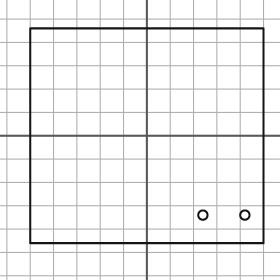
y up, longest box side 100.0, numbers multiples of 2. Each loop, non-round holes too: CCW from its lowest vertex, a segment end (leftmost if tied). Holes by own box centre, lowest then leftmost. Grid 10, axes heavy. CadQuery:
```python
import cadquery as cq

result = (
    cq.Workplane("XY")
    .moveTo(-50.0, -46.0)
    .lineTo(50.0, -46.0)
    .lineTo(50.0, 46.0)
    .lineTo(-50.0, 46.0)
    .close()
    .moveTo(24.0, -34.0)
    .circle(2.0)
    .moveTo(42.0, -34.0)
    .circle(2.0)
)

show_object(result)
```